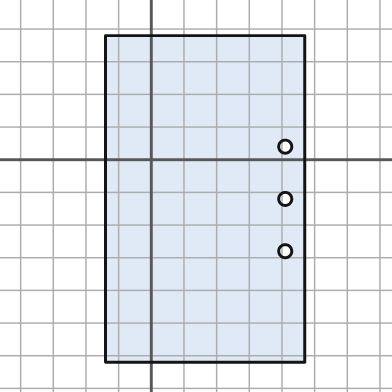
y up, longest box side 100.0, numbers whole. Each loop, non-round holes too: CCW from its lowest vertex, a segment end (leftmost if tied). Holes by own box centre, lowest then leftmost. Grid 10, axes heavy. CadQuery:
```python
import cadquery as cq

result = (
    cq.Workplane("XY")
    .moveTo(-14.0, -62.0)
    .lineTo(47.0, -62.0)
    .lineTo(47.0, 38.0)
    .lineTo(-14.0, 38.0)
    .close()
    .moveTo(41.0, -28.0)
    .circle(2.0)
    .moveTo(41.0, -12.0)
    .circle(2.0)
    .moveTo(41.0, 4.0)
    .circle(2.0)
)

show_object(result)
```